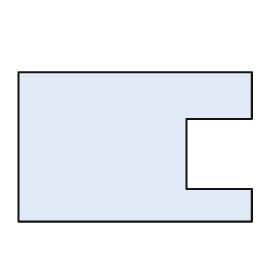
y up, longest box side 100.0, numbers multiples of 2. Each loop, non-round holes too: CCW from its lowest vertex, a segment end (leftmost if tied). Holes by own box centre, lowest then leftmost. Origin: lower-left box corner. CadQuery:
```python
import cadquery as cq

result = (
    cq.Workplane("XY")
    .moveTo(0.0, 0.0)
    .lineTo(100.0, 0.0)
    .lineTo(100.0, 14.0)
    .lineTo(72.0, 14.0)
    .lineTo(72.0, 44.0)
    .lineTo(100.0, 44.0)
    .lineTo(100.0, 64.0)
    .lineTo(0.0, 64.0)
    .close()
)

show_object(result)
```